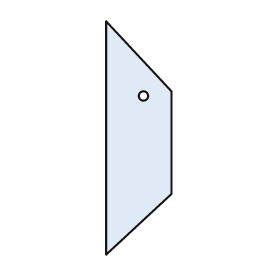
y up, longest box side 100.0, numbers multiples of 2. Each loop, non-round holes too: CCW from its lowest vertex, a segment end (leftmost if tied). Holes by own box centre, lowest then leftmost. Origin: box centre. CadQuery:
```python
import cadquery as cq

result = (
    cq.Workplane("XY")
    .moveTo(-14.0, -50.0)
    .lineTo(14.0, -24.0)
    .lineTo(14.0, 20.0)
    .lineTo(-14.0, 50.0)
    .close()
    .moveTo(2.0, 18.0)
    .circle(2.0)
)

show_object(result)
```